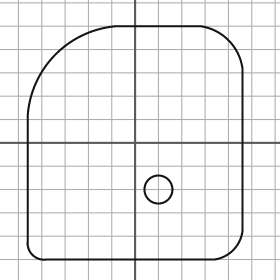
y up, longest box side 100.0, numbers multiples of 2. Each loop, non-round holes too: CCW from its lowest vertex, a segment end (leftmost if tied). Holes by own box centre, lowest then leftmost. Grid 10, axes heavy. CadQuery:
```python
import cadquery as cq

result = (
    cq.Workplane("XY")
    .moveTo(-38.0, -50.0)
    .lineTo(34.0, -50.0)
    .threePointArc((42.0, -46.0), (46.0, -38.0))
    .lineTo(46.0, 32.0)
    .threePointArc((40.0, 44.0), (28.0, 50.0))
    .lineTo(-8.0, 50.0)
    .threePointArc((-34.0, 38.0), (-46.0, 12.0))
    .lineTo(-46.0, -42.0)
    .threePointArc((-44.0, -48.0), (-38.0, -50.0))
    .close()
    .moveTo(10.0, -20.0)
    .circle(6.0)
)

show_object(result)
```